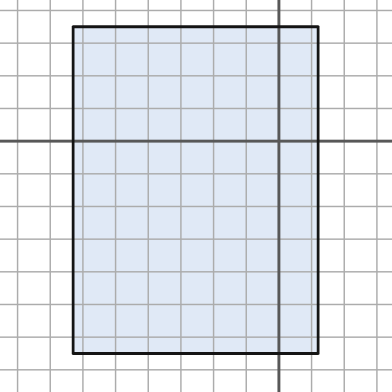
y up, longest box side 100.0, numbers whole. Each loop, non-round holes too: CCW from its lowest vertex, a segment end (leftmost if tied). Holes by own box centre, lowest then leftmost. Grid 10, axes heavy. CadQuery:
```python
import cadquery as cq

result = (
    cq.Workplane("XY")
    .moveTo(-63.0, -65.0)
    .lineTo(12.0, -65.0)
    .lineTo(12.0, 35.0)
    .lineTo(-63.0, 35.0)
    .close()
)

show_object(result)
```